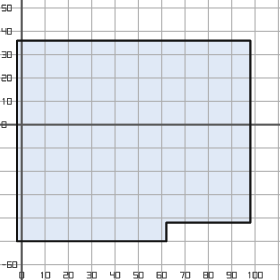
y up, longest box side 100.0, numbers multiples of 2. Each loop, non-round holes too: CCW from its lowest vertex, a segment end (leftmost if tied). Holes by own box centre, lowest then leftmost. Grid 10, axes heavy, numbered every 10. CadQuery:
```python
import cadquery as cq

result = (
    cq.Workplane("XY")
    .moveTo(-2.0, -50.0)
    .lineTo(62.0, -50.0)
    .lineTo(62.0, -42.0)
    .lineTo(98.0, -42.0)
    .lineTo(98.0, 36.0)
    .lineTo(-2.0, 36.0)
    .close()
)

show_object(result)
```